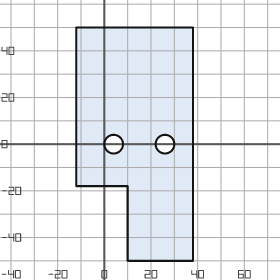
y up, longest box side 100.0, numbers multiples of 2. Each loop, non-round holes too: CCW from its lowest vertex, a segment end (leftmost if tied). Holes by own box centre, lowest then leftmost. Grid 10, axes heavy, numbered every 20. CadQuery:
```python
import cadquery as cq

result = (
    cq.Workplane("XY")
    .moveTo(10.0, -50.0)
    .lineTo(38.0, -50.0)
    .lineTo(38.0, 50.0)
    .lineTo(-12.0, 50.0)
    .lineTo(-12.0, -18.0)
    .lineTo(10.0, -18.0)
    .close()
    .moveTo(4.0, 0.0)
    .circle(4.0)
    .moveTo(26.0, 0.0)
    .circle(4.0)
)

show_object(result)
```